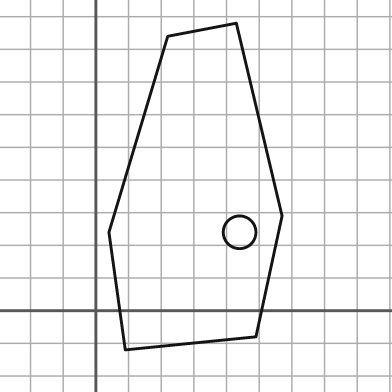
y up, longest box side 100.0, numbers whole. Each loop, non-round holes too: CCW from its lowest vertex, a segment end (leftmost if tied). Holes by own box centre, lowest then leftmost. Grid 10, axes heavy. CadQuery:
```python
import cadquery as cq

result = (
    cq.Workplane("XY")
    .moveTo(9.0, -12.0)
    .lineTo(49.0, -8.0)
    .lineTo(57.0, 29.0)
    .lineTo(43.0, 88.0)
    .lineTo(22.0, 84.0)
    .lineTo(4.0, 24.0)
    .close()
    .moveTo(44.0, 24.0)
    .circle(5.0)
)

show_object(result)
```